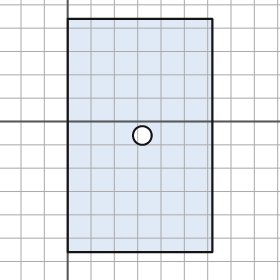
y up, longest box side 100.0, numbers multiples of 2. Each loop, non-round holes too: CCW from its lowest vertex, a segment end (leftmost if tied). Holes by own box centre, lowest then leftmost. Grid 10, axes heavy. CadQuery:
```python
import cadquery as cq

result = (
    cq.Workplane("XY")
    .moveTo(0.0, -56.0)
    .lineTo(62.0, -56.0)
    .lineTo(62.0, 44.0)
    .lineTo(0.0, 44.0)
    .close()
    .moveTo(32.0, -6.0)
    .circle(4.0)
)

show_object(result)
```